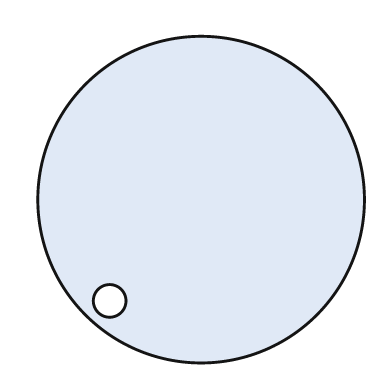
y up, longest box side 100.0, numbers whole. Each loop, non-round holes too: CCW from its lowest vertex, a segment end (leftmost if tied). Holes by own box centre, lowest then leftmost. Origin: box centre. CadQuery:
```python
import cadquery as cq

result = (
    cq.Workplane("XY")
    .moveTo(0.0, 0.0)
    .circle(50.0)
    .moveTo(-28.0, -31.0)
    .circle(5.0)
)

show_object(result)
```